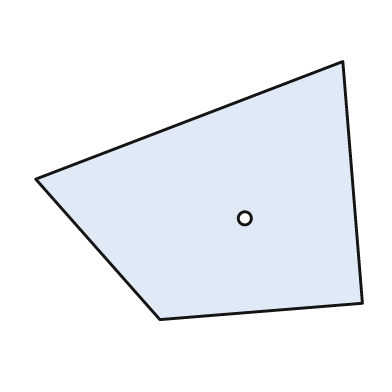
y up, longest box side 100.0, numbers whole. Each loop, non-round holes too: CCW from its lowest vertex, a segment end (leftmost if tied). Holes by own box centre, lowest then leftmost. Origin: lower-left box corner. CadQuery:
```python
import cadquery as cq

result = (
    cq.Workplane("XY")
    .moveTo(38.0, 0.0)
    .lineTo(100.0, 5.0)
    .lineTo(94.0, 79.0)
    .lineTo(0.0, 43.0)
    .close()
    .moveTo(64.0, 31.0)
    .circle(2.0)
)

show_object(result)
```